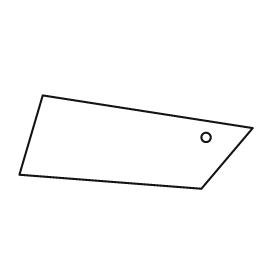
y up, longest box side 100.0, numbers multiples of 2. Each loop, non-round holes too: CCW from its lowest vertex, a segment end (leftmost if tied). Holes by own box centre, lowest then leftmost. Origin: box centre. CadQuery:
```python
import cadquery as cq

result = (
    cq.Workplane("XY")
    .moveTo(28.0, -20.0)
    .lineTo(50.0, 6.0)
    .lineTo(-40.0, 20.0)
    .lineTo(-50.0, -14.0)
    .close()
    .moveTo(30.0, 2.0)
    .circle(2.0)
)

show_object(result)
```